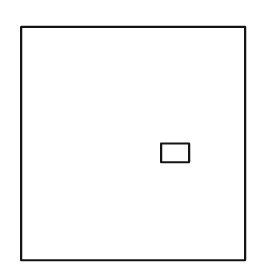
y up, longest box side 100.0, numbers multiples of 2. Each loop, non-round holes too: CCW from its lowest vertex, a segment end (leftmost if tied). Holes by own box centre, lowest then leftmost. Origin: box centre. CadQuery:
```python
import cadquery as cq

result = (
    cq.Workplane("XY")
    .moveTo(-48.0, -50.0)
    .lineTo(48.0, -50.0)
    .lineTo(48.0, 50.0)
    .lineTo(-48.0, 50.0)
    .close()
    .moveTo(12.0, -8.0)
    .lineTo(24.0, -8.0)
    .lineTo(24.0, 0.0)
    .lineTo(12.0, 0.0)
    .close()
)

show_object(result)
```